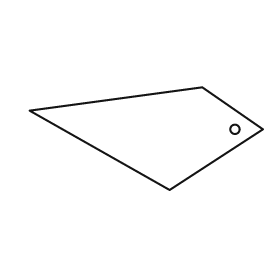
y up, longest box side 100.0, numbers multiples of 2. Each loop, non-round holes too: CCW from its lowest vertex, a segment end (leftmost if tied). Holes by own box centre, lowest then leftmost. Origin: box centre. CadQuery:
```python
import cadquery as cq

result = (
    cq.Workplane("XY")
    .moveTo(10.0, -22.0)
    .lineTo(50.0, 4.0)
    .lineTo(24.0, 22.0)
    .lineTo(-50.0, 12.0)
    .close()
    .moveTo(38.0, 4.0)
    .circle(2.0)
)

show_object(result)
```